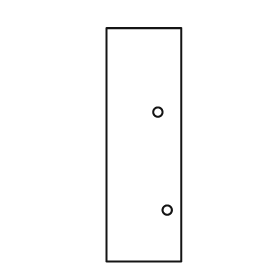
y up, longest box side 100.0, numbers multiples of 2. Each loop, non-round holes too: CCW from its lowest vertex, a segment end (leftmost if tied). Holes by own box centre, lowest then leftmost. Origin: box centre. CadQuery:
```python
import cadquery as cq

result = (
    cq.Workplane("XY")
    .moveTo(-16.0, -50.0)
    .lineTo(16.0, -50.0)
    .lineTo(16.0, 50.0)
    .lineTo(-16.0, 50.0)
    .close()
    .moveTo(10.0, -28.0)
    .circle(2.0)
    .moveTo(6.0, 14.0)
    .circle(2.0)
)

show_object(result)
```